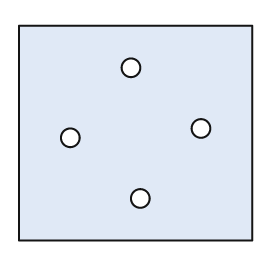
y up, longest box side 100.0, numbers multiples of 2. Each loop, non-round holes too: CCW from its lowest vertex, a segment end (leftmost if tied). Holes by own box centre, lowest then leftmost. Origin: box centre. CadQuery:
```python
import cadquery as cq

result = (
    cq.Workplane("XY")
    .moveTo(-50.0, -46.0)
    .lineTo(50.0, -46.0)
    .lineTo(50.0, 46.0)
    .lineTo(-50.0, 46.0)
    .close()
    .moveTo(2.0, -28.0)
    .circle(4.0)
    .moveTo(-28.0, -2.0)
    .circle(4.0)
    .moveTo(28.0, 2.0)
    .circle(4.0)
    .moveTo(-2.0, 28.0)
    .circle(4.0)
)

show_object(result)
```